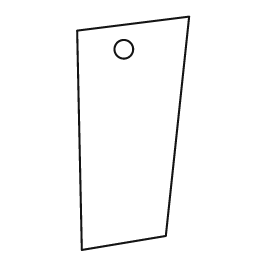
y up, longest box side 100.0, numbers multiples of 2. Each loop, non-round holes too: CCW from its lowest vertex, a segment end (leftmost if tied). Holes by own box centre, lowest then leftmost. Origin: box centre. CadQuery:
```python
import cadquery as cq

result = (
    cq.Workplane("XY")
    .moveTo(-22.0, -50.0)
    .lineTo(14.0, -44.0)
    .lineTo(24.0, 50.0)
    .lineTo(-24.0, 44.0)
    .close()
    .moveTo(-4.0, 36.0)
    .circle(4.0)
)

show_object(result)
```